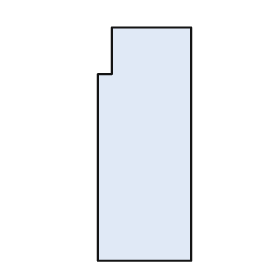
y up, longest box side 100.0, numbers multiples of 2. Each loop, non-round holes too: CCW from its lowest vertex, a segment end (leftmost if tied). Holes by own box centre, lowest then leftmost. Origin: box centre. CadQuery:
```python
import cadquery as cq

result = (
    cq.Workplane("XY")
    .moveTo(-20.0, -50.0)
    .lineTo(20.0, -50.0)
    .lineTo(20.0, 50.0)
    .lineTo(-14.0, 50.0)
    .lineTo(-14.0, 30.0)
    .lineTo(-20.0, 30.0)
    .close()
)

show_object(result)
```